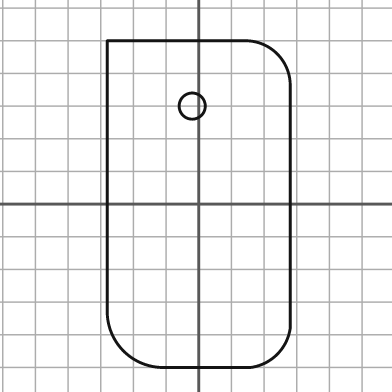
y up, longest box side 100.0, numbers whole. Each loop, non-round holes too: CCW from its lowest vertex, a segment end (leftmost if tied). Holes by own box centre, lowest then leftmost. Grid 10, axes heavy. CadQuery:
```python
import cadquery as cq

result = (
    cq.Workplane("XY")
    .moveTo(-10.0, -50.0)
    .lineTo(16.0, -50.0)
    .threePointArc((24.0, -46.0), (28.0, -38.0))
    .lineTo(28.0, 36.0)
    .threePointArc((24.0, 46.0), (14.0, 50.0))
    .lineTo(-28.0, 50.0)
    .lineTo(-28.0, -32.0)
    .threePointArc((-23.0, -45.0), (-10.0, -50.0))
    .close()
    .moveTo(-2.0, 30.0)
    .circle(4.0)
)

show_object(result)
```